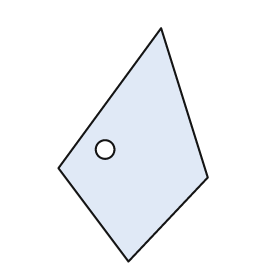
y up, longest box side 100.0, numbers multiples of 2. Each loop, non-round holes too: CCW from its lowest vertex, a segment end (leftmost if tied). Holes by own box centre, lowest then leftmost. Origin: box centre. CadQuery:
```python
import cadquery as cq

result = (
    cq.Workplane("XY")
    .moveTo(-2.0, -50.0)
    .lineTo(32.0, -14.0)
    .lineTo(12.0, 50.0)
    .lineTo(-32.0, -10.0)
    .close()
    .moveTo(-12.0, -2.0)
    .circle(4.0)
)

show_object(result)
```